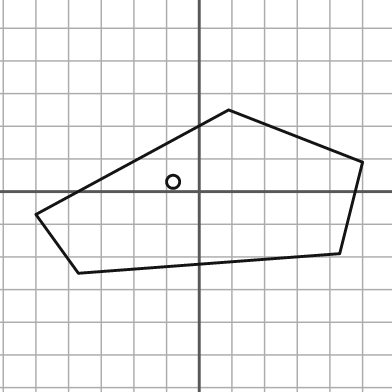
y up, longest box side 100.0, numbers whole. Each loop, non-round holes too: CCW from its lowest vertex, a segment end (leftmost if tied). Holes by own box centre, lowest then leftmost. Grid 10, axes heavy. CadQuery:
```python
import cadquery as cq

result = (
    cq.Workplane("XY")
    .moveTo(-37.0, -25.0)
    .lineTo(43.0, -19.0)
    .lineTo(50.0, 9.0)
    .lineTo(9.0, 25.0)
    .lineTo(-50.0, -7.0)
    .close()
    .moveTo(-8.0, 3.0)
    .circle(2.0)
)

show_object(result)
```